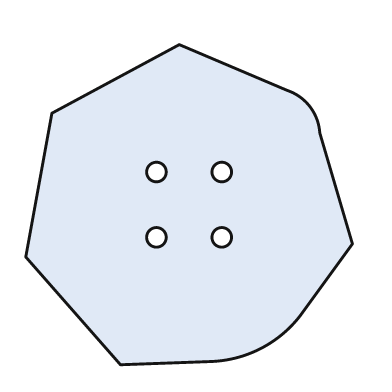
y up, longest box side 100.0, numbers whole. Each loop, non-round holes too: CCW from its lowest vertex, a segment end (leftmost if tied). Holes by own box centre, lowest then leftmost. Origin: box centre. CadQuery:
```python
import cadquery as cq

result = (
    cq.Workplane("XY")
    .moveTo(-21.0, -49.0)
    .lineTo(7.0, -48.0)
    .threePointArc((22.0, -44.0), (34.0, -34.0))
    .lineTo(50.0, -12.0)
    .lineTo(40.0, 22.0)
    .threePointArc((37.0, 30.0), (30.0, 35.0))
    .lineTo(-3.0, 49.0)
    .lineTo(-42.0, 28.0)
    .lineTo(-50.0, -16.0)
    .close()
    .moveTo(-10.0, -10.0)
    .circle(3.0)
    .moveTo(10.0, -10.0)
    .circle(3.0)
    .moveTo(-10.0, 10.0)
    .circle(3.0)
    .moveTo(10.0, 10.0)
    .circle(3.0)
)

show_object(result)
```